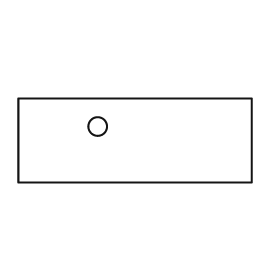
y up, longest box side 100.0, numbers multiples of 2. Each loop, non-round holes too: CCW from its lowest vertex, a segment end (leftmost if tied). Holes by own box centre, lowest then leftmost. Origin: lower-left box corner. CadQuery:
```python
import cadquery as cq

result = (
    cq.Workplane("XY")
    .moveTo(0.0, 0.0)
    .lineTo(100.0, 0.0)
    .lineTo(100.0, 36.0)
    .lineTo(0.0, 36.0)
    .close()
    .moveTo(34.0, 24.0)
    .circle(4.0)
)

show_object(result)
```